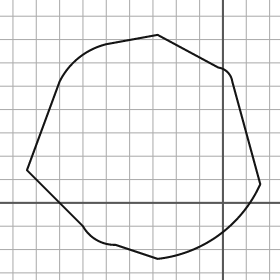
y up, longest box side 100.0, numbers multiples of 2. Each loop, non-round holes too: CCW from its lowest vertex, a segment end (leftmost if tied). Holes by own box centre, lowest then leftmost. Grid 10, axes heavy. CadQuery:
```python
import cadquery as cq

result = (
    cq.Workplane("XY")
    .moveTo(-28.0, -24.0)
    .threePointArc((-2.0, -14.0), (16.0, 8.0))
    .lineTo(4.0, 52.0)
    .threePointArc((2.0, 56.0), (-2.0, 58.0))
    .lineTo(-28.0, 72.0)
    .lineTo(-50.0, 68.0)
    .threePointArc((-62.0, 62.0), (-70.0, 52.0))
    .lineTo(-84.0, 14.0)
    .lineTo(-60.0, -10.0)
    .threePointArc((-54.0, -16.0), (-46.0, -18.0))
    .close()
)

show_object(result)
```